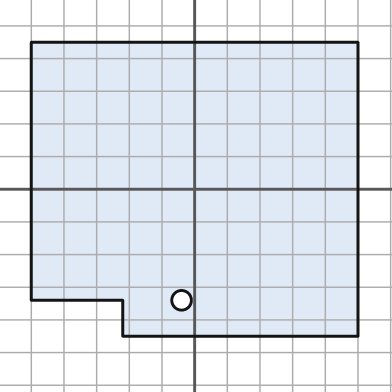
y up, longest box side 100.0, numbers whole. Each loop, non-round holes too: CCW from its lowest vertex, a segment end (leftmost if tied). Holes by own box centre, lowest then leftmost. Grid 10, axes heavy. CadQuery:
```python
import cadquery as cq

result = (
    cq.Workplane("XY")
    .moveTo(-22.0, -45.0)
    .lineTo(50.0, -45.0)
    .lineTo(50.0, 45.0)
    .lineTo(-50.0, 45.0)
    .lineTo(-50.0, -34.0)
    .lineTo(-22.0, -34.0)
    .close()
    .moveTo(-4.0, -34.0)
    .circle(3.0)
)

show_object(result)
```